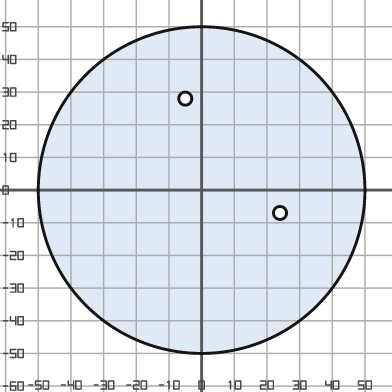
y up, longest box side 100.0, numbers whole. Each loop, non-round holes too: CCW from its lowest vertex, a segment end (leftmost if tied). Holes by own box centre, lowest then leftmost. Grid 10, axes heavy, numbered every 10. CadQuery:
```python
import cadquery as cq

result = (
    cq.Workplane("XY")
    .moveTo(0.0, 0.0)
    .circle(50.0)
    .moveTo(24.0, -7.0)
    .circle(2.0)
    .moveTo(-5.0, 28.0)
    .circle(2.0)
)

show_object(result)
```